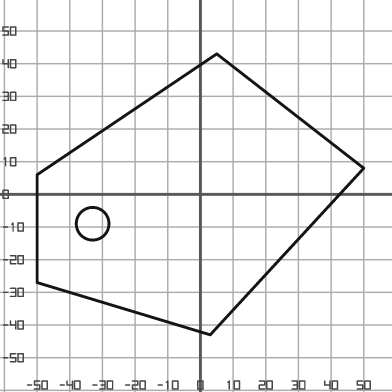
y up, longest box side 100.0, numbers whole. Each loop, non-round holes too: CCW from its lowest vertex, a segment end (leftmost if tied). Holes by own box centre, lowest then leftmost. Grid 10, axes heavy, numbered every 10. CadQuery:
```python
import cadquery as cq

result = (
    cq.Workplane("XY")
    .moveTo(3.0, -43.0)
    .lineTo(50.0, 8.0)
    .lineTo(5.0, 43.0)
    .lineTo(-50.0, 6.0)
    .lineTo(-50.0, -27.0)
    .close()
    .moveTo(-33.0, -9.0)
    .circle(5.0)
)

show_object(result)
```